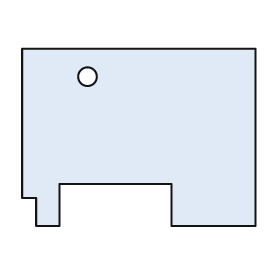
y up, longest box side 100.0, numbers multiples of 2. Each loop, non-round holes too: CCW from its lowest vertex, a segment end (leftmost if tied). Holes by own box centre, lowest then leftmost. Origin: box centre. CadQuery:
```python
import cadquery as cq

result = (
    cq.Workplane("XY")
    .moveTo(-44.0, -38.0)
    .lineTo(-34.0, -38.0)
    .lineTo(-34.0, -20.0)
    .lineTo(14.0, -20.0)
    .lineTo(14.0, -38.0)
    .lineTo(50.0, -38.0)
    .lineTo(50.0, 38.0)
    .lineTo(-50.0, 38.0)
    .lineTo(-50.0, -26.0)
    .lineTo(-44.0, -26.0)
    .close()
    .moveTo(-22.0, 26.0)
    .circle(4.0)
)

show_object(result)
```